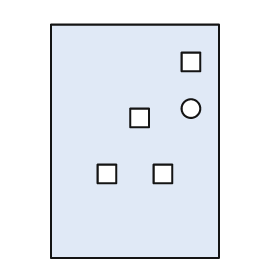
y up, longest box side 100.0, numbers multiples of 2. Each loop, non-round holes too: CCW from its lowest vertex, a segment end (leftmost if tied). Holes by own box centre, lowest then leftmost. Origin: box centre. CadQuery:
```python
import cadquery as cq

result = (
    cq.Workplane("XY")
    .moveTo(-36.0, -50.0)
    .lineTo(36.0, -50.0)
    .lineTo(36.0, 50.0)
    .lineTo(-36.0, 50.0)
    .close()
    .moveTo(-16.0, -18.0)
    .lineTo(-8.0, -18.0)
    .lineTo(-8.0, -10.0)
    .lineTo(-16.0, -10.0)
    .close()
    .moveTo(8.0, -18.0)
    .lineTo(16.0, -18.0)
    .lineTo(16.0, -10.0)
    .lineTo(8.0, -10.0)
    .close()
    .moveTo(-2.0, 6.0)
    .lineTo(6.0, 6.0)
    .lineTo(6.0, 14.0)
    .lineTo(-2.0, 14.0)
    .close()
    .moveTo(24.0, 14.0)
    .circle(4.0)
    .moveTo(20.0, 30.0)
    .lineTo(28.0, 30.0)
    .lineTo(28.0, 38.0)
    .lineTo(20.0, 38.0)
    .close()
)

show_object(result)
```